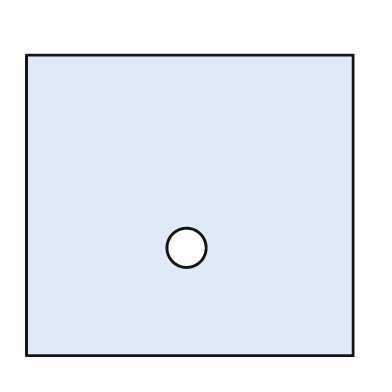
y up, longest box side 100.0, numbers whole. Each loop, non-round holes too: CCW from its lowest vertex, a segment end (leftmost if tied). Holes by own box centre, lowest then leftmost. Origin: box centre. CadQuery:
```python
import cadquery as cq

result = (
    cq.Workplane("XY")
    .moveTo(-50.0, -46.0)
    .lineTo(50.0, -46.0)
    .lineTo(50.0, 46.0)
    .lineTo(-50.0, 46.0)
    .close()
    .moveTo(-1.0, -13.0)
    .circle(6.0)
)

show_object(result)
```